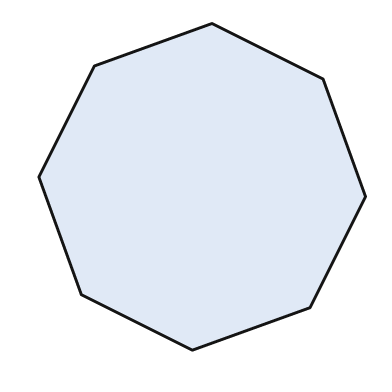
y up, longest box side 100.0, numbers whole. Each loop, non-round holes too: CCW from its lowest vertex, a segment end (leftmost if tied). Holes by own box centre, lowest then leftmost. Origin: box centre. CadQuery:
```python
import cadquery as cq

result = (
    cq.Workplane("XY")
    .moveTo(-3.0, -50.0)
    .lineTo(33.0, -37.0)
    .lineTo(50.0, -3.0)
    .lineTo(37.0, 33.0)
    .lineTo(3.0, 50.0)
    .lineTo(-33.0, 37.0)
    .lineTo(-50.0, 3.0)
    .lineTo(-37.0, -33.0)
    .close()
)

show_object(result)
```